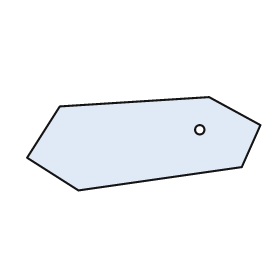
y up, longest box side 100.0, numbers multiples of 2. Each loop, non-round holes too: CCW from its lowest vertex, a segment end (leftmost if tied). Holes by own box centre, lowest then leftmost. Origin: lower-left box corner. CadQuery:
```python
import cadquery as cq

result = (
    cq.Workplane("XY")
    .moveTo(22.0, 0.0)
    .lineTo(92.0, 10.0)
    .lineTo(100.0, 28.0)
    .lineTo(78.0, 40.0)
    .lineTo(14.0, 36.0)
    .lineTo(0.0, 14.0)
    .close()
    .moveTo(74.0, 26.0)
    .circle(2.0)
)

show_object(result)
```